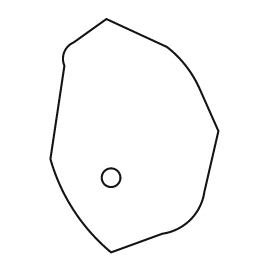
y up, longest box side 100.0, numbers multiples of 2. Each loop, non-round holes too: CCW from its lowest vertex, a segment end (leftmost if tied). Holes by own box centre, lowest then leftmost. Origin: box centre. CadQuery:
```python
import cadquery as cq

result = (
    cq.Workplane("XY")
    .moveTo(-10.0, -50.0)
    .lineTo(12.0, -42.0)
    .threePointArc((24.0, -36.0), (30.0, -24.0))
    .lineTo(36.0, 2.0)
    .lineTo(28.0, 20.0)
    .threePointArc((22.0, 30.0), (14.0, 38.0))
    .lineTo(-12.0, 50.0)
    .lineTo(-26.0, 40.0)
    .threePointArc((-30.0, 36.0), (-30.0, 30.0))
    .lineTo(-36.0, -10.0)
    .threePointArc((-26.0, -32.0), (-10.0, -50.0))
    .close()
    .moveTo(-10.0, -18.0)
    .circle(4.0)
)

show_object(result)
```